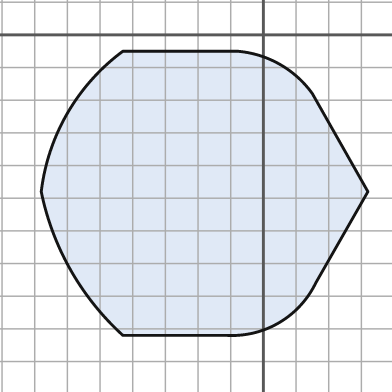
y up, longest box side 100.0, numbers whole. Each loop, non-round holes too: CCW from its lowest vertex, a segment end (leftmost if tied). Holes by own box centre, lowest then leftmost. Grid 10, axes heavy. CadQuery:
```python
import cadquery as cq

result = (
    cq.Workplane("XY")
    .moveTo(-43.0, -92.0)
    .lineTo(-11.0, -92.0)
    .threePointArc((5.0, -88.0), (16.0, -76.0))
    .lineTo(32.0, -48.0)
    .lineTo(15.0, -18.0)
    .threePointArc((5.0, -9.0), (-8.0, -5.0))
    .lineTo(-43.0, -5.0)
    .threePointArc((-60.0, -24.0), (-68.0, -48.0))
    .threePointArc((-59.0, -72.0), (-43.0, -92.0))
    .close()
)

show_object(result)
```